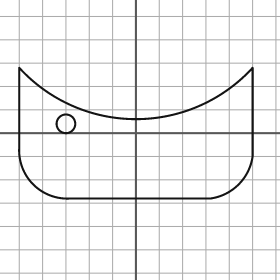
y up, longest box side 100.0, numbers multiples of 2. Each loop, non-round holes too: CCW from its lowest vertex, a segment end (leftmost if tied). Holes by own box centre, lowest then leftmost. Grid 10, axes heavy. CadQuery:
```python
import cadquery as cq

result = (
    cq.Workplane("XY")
    .moveTo(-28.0, -28.0)
    .lineTo(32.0, -28.0)
    .threePointArc((44.0, -22.0), (50.0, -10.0))
    .lineTo(50.0, 28.0)
    .threePointArc((0.0, 6.0), (-50.0, 28.0))
    .lineTo(-50.0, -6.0)
    .threePointArc((-44.0, -22.0), (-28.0, -28.0))
    .close()
    .moveTo(-30.0, 4.0)
    .circle(4.0)
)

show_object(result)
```